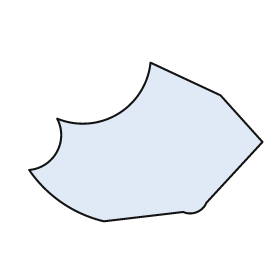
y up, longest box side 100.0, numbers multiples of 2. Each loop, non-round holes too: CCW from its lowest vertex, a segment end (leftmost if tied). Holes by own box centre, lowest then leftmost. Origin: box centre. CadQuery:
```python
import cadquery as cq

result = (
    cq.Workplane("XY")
    .moveTo(-18.0, -34.0)
    .lineTo(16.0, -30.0)
    .threePointArc((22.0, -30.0), (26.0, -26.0))
    .lineTo(50.0, 0.0)
    .lineTo(32.0, 20.0)
    .lineTo(2.0, 34.0)
    .threePointArc((-12.0, 12.0), (-38.0, 10.0))
    .threePointArc((-38.0, -4.0), (-50.0, -12.0))
    .threePointArc((-36.0, -26.0), (-18.0, -34.0))
    .close()
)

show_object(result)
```